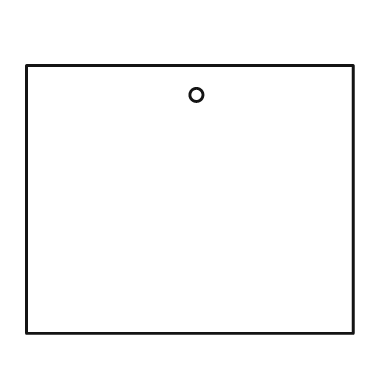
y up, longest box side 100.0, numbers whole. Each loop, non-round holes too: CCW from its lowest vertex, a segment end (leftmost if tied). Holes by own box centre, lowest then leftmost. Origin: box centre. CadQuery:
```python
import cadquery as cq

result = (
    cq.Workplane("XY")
    .moveTo(-50.0, -41.0)
    .lineTo(50.0, -41.0)
    .lineTo(50.0, 41.0)
    .lineTo(-50.0, 41.0)
    .close()
    .moveTo(2.0, 32.0)
    .circle(2.0)
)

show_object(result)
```